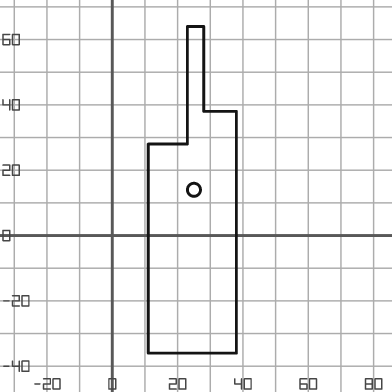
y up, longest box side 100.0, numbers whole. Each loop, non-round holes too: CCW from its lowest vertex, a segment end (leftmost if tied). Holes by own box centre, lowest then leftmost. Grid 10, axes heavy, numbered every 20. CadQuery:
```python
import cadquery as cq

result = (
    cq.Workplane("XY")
    .moveTo(11.0, -36.0)
    .lineTo(38.0, -36.0)
    .lineTo(38.0, 38.0)
    .lineTo(28.0, 38.0)
    .lineTo(28.0, 64.0)
    .lineTo(23.0, 64.0)
    .lineTo(23.0, 28.0)
    .lineTo(11.0, 28.0)
    .close()
    .moveTo(25.0, 14.0)
    .circle(2.0)
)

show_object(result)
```